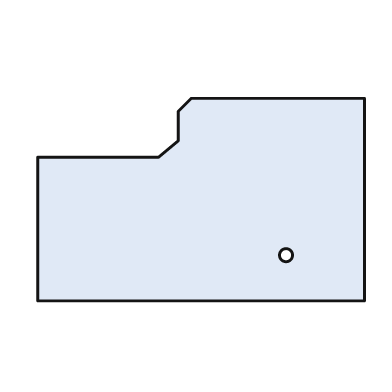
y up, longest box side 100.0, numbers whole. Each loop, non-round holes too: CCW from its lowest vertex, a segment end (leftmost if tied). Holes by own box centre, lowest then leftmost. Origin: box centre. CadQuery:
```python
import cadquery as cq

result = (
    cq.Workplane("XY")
    .moveTo(-50.0, -31.0)
    .lineTo(50.0, -31.0)
    .lineTo(50.0, 31.0)
    .lineTo(-3.0, 31.0)
    .lineTo(-7.0, 27.0)
    .lineTo(-7.0, 18.0)
    .lineTo(-13.0, 13.0)
    .lineTo(-50.0, 13.0)
    .close()
    .moveTo(26.0, -17.0)
    .circle(2.0)
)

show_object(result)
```